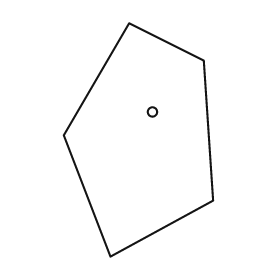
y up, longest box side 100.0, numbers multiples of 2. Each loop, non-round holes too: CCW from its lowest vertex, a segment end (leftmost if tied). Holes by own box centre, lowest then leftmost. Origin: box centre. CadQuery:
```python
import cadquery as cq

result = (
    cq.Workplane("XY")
    .moveTo(-12.0, -50.0)
    .lineTo(32.0, -26.0)
    .lineTo(28.0, 34.0)
    .lineTo(-4.0, 50.0)
    .lineTo(-32.0, 2.0)
    .close()
    .moveTo(6.0, 12.0)
    .circle(2.0)
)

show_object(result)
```